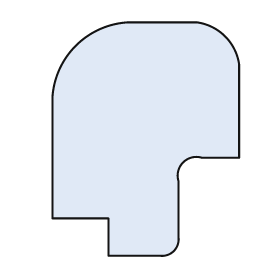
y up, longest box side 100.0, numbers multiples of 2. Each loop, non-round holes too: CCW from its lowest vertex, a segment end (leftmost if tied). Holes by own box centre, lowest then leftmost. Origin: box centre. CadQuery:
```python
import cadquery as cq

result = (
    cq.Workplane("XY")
    .moveTo(-16.0, -50.0)
    .lineTo(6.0, -50.0)
    .threePointArc((12.0, -48.0), (14.0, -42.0))
    .lineTo(14.0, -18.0)
    .threePointArc((16.0, -10.0), (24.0, -8.0))
    .lineTo(40.0, -8.0)
    .lineTo(40.0, 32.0)
    .threePointArc((34.0, 44.0), (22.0, 50.0))
    .lineTo(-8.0, 50.0)
    .threePointArc((-30.0, 40.0), (-40.0, 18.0))
    .lineTo(-40.0, -34.0)
    .lineTo(-16.0, -34.0)
    .close()
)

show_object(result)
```